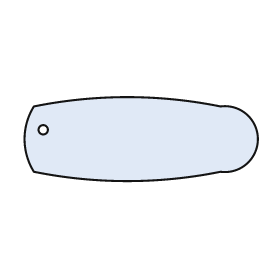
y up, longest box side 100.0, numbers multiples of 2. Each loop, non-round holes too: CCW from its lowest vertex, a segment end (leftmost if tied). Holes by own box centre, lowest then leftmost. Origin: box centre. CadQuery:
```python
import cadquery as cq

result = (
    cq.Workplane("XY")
    .moveTo(-46.0, -14.0)
    .threePointArc((-6.0, -18.0), (34.0, -14.0))
    .threePointArc((50.0, 0.0), (34.0, 14.0))
    .threePointArc((-6.0, 18.0), (-46.0, 14.0))
    .threePointArc((-50.0, 0.0), (-46.0, -14.0))
    .close()
    .moveTo(-42.0, 4.0)
    .circle(2.0)
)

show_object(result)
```